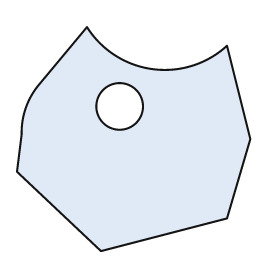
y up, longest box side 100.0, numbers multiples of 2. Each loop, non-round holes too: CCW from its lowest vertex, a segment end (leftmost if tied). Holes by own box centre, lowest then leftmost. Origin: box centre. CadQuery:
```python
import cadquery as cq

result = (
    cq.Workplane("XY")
    .moveTo(-14.0, -48.0)
    .lineTo(40.0, -34.0)
    .lineTo(50.0, 0.0)
    .lineTo(40.0, 40.0)
    .threePointArc((8.0, 30.0), (-20.0, 48.0))
    .lineTo(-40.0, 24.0)
    .threePointArc((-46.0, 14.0), (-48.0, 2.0))
    .lineTo(-50.0, -14.0)
    .close()
    .moveTo(-6.0, 14.0)
    .circle(10.0)
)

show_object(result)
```